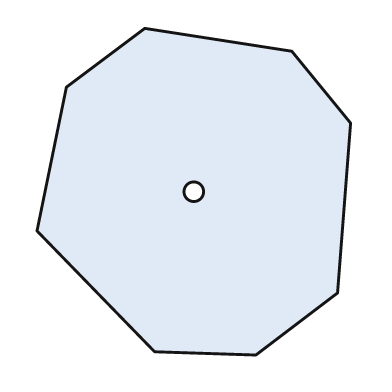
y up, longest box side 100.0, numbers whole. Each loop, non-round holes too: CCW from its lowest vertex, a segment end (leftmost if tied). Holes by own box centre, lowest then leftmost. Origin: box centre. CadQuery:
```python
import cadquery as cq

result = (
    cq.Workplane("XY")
    .moveTo(19.0, -50.0)
    .lineTo(44.0, -31.0)
    .lineTo(48.0, 21.0)
    .lineTo(30.0, 43.0)
    .lineTo(-15.0, 50.0)
    .lineTo(-39.0, 32.0)
    .lineTo(-48.0, -12.0)
    .lineTo(-12.0, -49.0)
    .close()
    .moveTo(0.0, 0.0)
    .circle(3.0)
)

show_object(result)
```